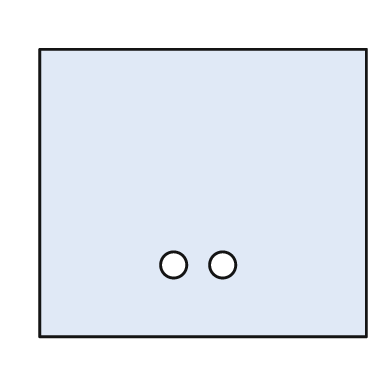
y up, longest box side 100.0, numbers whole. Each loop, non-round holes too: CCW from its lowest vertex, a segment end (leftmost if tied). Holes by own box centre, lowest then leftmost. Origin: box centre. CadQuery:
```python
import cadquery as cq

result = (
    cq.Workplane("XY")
    .moveTo(-50.0, -44.0)
    .lineTo(50.0, -44.0)
    .lineTo(50.0, 44.0)
    .lineTo(-50.0, 44.0)
    .close()
    .moveTo(-9.0, -22.0)
    .circle(4.0)
    .moveTo(6.0, -22.0)
    .circle(4.0)
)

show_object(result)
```